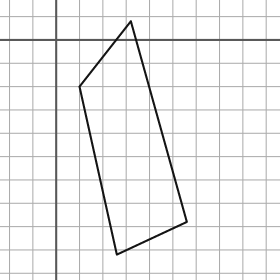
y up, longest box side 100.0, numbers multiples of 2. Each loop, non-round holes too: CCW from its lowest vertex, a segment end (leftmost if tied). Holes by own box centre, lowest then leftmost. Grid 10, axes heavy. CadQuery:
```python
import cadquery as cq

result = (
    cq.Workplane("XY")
    .moveTo(26.0, -92.0)
    .lineTo(56.0, -78.0)
    .lineTo(32.0, 8.0)
    .lineTo(10.0, -20.0)
    .close()
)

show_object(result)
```